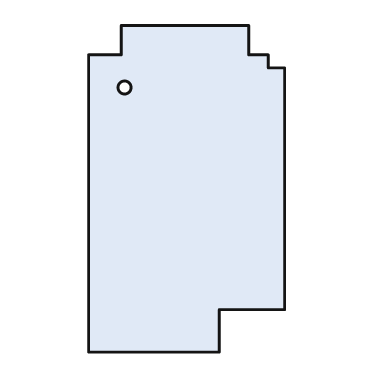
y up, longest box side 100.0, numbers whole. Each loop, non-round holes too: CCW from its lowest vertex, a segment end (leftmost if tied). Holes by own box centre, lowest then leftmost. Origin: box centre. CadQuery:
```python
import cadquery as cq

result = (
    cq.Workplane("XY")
    .moveTo(-30.0, -50.0)
    .lineTo(10.0, -50.0)
    .lineTo(10.0, -37.0)
    .lineTo(30.0, -37.0)
    .lineTo(30.0, 37.0)
    .lineTo(25.0, 37.0)
    .lineTo(25.0, 41.0)
    .lineTo(19.0, 41.0)
    .lineTo(19.0, 50.0)
    .lineTo(-20.0, 50.0)
    .lineTo(-20.0, 41.0)
    .lineTo(-30.0, 41.0)
    .close()
    .moveTo(-19.0, 31.0)
    .circle(2.0)
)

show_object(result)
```